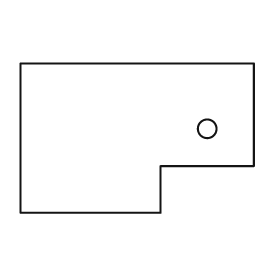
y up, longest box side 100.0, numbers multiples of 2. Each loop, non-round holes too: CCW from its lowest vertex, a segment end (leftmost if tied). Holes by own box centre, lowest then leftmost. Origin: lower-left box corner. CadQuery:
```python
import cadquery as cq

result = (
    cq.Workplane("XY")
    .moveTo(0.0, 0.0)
    .lineTo(60.0, 0.0)
    .lineTo(60.0, 20.0)
    .lineTo(100.0, 20.0)
    .lineTo(100.0, 64.0)
    .lineTo(0.0, 64.0)
    .close()
    .moveTo(80.0, 36.0)
    .circle(4.0)
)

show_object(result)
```